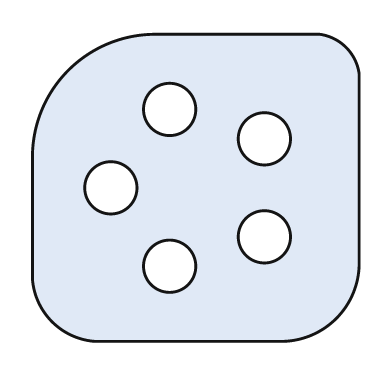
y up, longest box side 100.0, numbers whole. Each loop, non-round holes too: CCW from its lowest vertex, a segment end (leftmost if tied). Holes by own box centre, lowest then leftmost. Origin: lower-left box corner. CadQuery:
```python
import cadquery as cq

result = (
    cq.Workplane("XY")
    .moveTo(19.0, 0.0)
    .lineTo(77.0, 0.0)
    .threePointArc((93.0, 7.0), (100.0, 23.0))
    .lineTo(100.0, 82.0)
    .threePointArc((96.0, 90.0), (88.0, 94.0))
    .lineTo(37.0, 94.0)
    .threePointArc((11.0, 83.0), (0.0, 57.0))
    .lineTo(0.0, 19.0)
    .threePointArc((6.0, 6.0), (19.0, 0.0))
    .close()
    .moveTo(42.0, 23.0)
    .circle(8.0)
    .moveTo(71.0, 32.0)
    .circle(8.0)
    .moveTo(24.0, 47.0)
    .circle(8.0)
    .moveTo(71.0, 62.0)
    .circle(8.0)
    .moveTo(42.0, 71.0)
    .circle(8.0)
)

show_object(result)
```